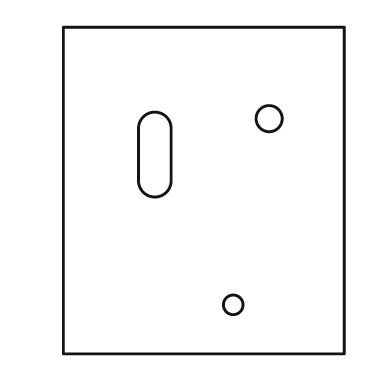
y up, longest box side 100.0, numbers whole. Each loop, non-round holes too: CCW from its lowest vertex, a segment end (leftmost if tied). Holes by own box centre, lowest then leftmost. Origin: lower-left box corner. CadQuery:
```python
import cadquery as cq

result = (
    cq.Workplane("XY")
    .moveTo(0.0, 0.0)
    .lineTo(86.0, 0.0)
    .lineTo(86.0, 100.0)
    .lineTo(0.0, 100.0)
    .close()
    .moveTo(52.0, 15.0)
    .circle(3.0)
    .moveTo(23.0, 53.0)
    .threePointArc((28.0, 48.0), (33.0, 53.0))
    .lineTo(33.0, 69.0)
    .threePointArc((28.0, 74.0), (23.0, 69.0))
    .close()
    .moveTo(63.0, 72.0)
    .circle(4.0)
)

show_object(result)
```